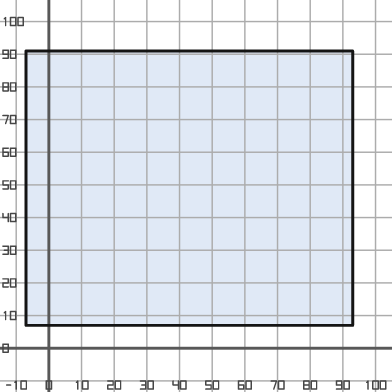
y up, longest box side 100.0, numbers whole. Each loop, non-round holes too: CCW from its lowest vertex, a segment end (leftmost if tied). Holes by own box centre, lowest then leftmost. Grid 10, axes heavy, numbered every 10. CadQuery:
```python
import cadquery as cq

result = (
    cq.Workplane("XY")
    .moveTo(-7.0, 7.0)
    .lineTo(93.0, 7.0)
    .lineTo(93.0, 91.0)
    .lineTo(-7.0, 91.0)
    .close()
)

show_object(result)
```